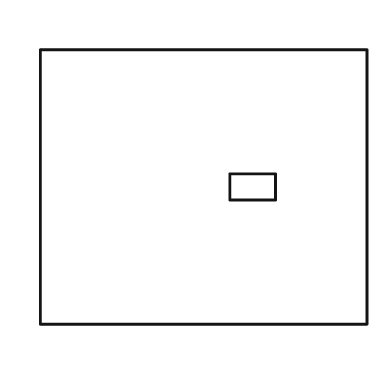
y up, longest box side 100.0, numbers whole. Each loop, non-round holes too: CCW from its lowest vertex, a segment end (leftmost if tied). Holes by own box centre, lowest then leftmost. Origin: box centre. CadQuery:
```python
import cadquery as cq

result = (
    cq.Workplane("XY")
    .moveTo(-50.0, -42.0)
    .lineTo(50.0, -42.0)
    .lineTo(50.0, 42.0)
    .lineTo(-50.0, 42.0)
    .close()
    .moveTo(8.0, -4.0)
    .lineTo(22.0, -4.0)
    .lineTo(22.0, 4.0)
    .lineTo(8.0, 4.0)
    .close()
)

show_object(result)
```